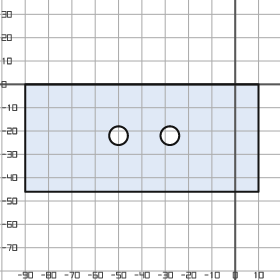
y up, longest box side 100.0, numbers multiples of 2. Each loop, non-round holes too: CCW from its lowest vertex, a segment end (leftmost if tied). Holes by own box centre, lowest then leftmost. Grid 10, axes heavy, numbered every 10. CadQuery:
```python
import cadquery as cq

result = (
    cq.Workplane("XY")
    .moveTo(-90.0, -46.0)
    .lineTo(10.0, -46.0)
    .lineTo(10.0, 0.0)
    .lineTo(-90.0, 0.0)
    .close()
    .moveTo(-50.0, -22.0)
    .circle(4.0)
    .moveTo(-28.0, -22.0)
    .circle(4.0)
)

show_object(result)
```